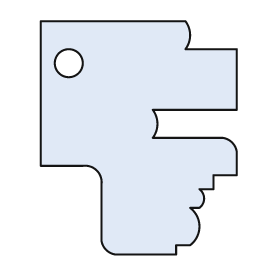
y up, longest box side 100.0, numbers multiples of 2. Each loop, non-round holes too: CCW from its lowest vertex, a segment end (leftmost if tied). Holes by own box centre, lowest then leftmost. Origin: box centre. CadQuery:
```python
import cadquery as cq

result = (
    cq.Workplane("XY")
    .moveTo(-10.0, -50.0)
    .lineTo(16.0, -50.0)
    .lineTo(16.0, -46.0)
    .lineTo(22.0, -46.0)
    .threePointArc((26.0, -38.0), (22.0, -30.0))
    .lineTo(26.0, -30.0)
    .threePointArc((28.0, -26.0), (26.0, -22.0))
    .lineTo(32.0, -22.0)
    .lineTo(32.0, -16.0)
    .lineTo(42.0, -16.0)
    .lineTo(42.0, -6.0)
    .threePointArc((40.0, -2.0), (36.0, 0.0))
    .lineTo(6.0, 0.0)
    .threePointArc((8.0, 6.0), (6.0, 12.0))
    .lineTo(42.0, 12.0)
    .lineTo(42.0, 38.0)
    .lineTo(20.0, 38.0)
    .threePointArc((22.0, 44.0), (20.0, 50.0))
    .lineTo(-42.0, 50.0)
    .lineTo(-42.0, -12.0)
    .lineTo(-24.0, -12.0)
    .threePointArc((-18.0, -14.0), (-16.0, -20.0))
    .lineTo(-16.0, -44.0)
    .threePointArc((-14.0, -48.0), (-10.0, -50.0))
    .close()
    .moveTo(-30.0, 32.0)
    .circle(6.0)
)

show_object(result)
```